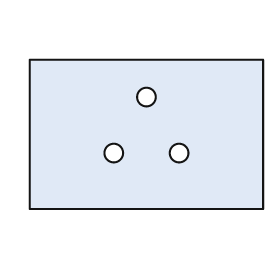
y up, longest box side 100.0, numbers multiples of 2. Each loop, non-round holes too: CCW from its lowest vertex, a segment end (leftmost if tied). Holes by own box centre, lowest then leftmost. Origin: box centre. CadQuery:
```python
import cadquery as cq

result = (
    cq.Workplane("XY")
    .moveTo(-50.0, -32.0)
    .lineTo(50.0, -32.0)
    .lineTo(50.0, 32.0)
    .lineTo(-50.0, 32.0)
    .close()
    .moveTo(-14.0, -8.0)
    .circle(4.0)
    .moveTo(14.0, -8.0)
    .circle(4.0)
    .moveTo(0.0, 16.0)
    .circle(4.0)
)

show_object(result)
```